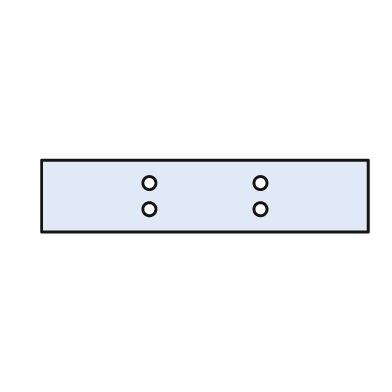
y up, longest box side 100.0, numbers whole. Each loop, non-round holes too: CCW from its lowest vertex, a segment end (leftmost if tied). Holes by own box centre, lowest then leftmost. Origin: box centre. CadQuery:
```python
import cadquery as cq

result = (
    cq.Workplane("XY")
    .moveTo(-50.0, -11.0)
    .lineTo(50.0, -11.0)
    .lineTo(50.0, 11.0)
    .lineTo(-50.0, 11.0)
    .close()
    .moveTo(-17.0, -4.0)
    .circle(2.0)
    .moveTo(17.0, -4.0)
    .circle(2.0)
    .moveTo(-17.0, 4.0)
    .circle(2.0)
    .moveTo(17.0, 4.0)
    .circle(2.0)
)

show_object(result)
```